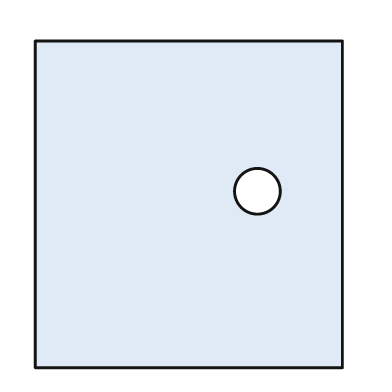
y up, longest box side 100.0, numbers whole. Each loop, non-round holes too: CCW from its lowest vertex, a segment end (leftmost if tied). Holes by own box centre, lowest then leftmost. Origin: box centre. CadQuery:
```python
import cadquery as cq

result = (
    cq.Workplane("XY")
    .moveTo(-47.0, -50.0)
    .lineTo(47.0, -50.0)
    .lineTo(47.0, 50.0)
    .lineTo(-47.0, 50.0)
    .close()
    .moveTo(21.0, 4.0)
    .circle(7.0)
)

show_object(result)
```